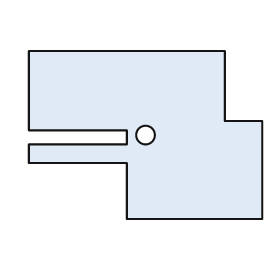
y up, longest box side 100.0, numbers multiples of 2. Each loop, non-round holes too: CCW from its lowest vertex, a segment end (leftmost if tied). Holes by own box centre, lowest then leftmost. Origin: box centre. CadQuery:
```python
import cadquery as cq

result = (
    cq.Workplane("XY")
    .moveTo(-8.0, -36.0)
    .lineTo(50.0, -36.0)
    .lineTo(50.0, 6.0)
    .lineTo(34.0, 6.0)
    .lineTo(34.0, 36.0)
    .lineTo(-50.0, 36.0)
    .lineTo(-50.0, 2.0)
    .lineTo(-8.0, 2.0)
    .lineTo(-8.0, -4.0)
    .lineTo(-50.0, -4.0)
    .lineTo(-50.0, -12.0)
    .lineTo(-8.0, -12.0)
    .close()
    .moveTo(0.0, 0.0)
    .circle(4.0)
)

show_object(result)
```